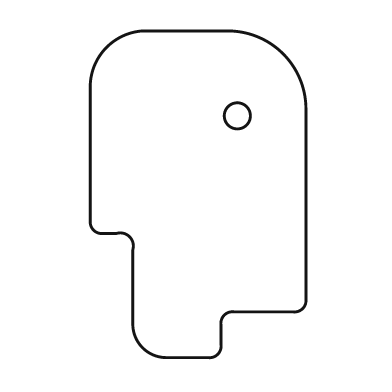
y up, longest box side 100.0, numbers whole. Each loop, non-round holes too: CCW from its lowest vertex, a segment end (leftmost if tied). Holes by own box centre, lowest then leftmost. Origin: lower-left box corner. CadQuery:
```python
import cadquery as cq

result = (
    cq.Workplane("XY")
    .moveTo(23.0, 0.0)
    .lineTo(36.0, 0.0)
    .threePointArc((39.0, 1.0), (40.0, 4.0))
    .lineTo(40.0, 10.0)
    .threePointArc((41.0, 13.0), (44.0, 14.0))
    .lineTo(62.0, 14.0)
    .threePointArc((65.0, 15.0), (66.0, 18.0))
    .lineTo(66.0, 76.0)
    .threePointArc((59.0, 93.0), (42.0, 100.0))
    .lineTo(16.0, 100.0)
    .threePointArc((5.0, 95.0), (0.0, 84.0))
    .lineTo(0.0, 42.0)
    .threePointArc((1.0, 39.0), (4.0, 38.0))
    .lineTo(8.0, 38.0)
    .threePointArc((12.0, 37.0), (13.0, 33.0))
    .lineTo(13.0, 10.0)
    .threePointArc((16.0, 3.0), (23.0, 0.0))
    .close()
    .moveTo(45.0, 74.0)
    .circle(4.0)
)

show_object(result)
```